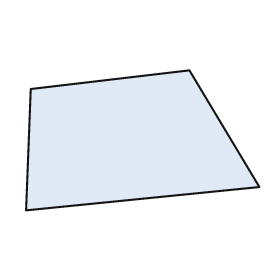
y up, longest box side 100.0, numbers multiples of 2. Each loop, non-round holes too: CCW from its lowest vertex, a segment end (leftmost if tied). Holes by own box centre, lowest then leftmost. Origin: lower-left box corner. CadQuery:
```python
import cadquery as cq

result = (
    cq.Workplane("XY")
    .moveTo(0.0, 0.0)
    .lineTo(100.0, 10.0)
    .lineTo(70.0, 60.0)
    .lineTo(2.0, 52.0)
    .close()
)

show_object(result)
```